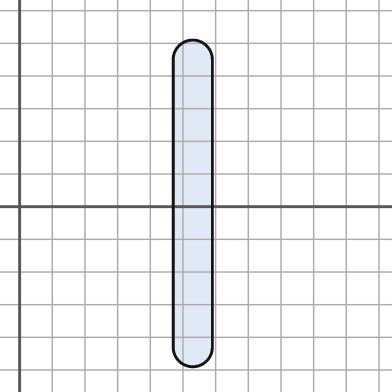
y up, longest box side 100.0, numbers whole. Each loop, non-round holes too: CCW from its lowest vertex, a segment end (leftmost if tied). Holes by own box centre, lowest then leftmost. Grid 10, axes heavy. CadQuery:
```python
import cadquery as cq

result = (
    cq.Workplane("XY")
    .moveTo(47.0, -43.0)
    .threePointArc((53.0, -49.0), (59.0, -43.0))
    .lineTo(59.0, 45.0)
    .threePointArc((53.0, 51.0), (47.0, 45.0))
    .close()
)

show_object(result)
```